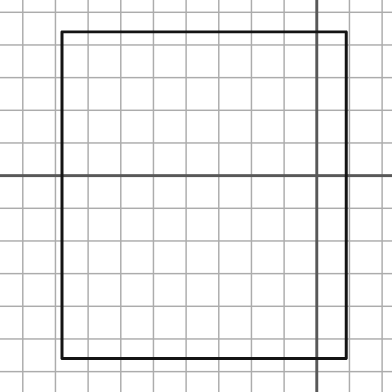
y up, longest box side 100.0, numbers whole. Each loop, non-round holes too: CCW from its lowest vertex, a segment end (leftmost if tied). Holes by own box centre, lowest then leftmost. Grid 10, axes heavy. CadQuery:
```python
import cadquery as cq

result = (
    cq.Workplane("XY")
    .moveTo(-78.0, -56.0)
    .lineTo(9.0, -56.0)
    .lineTo(9.0, 44.0)
    .lineTo(-78.0, 44.0)
    .close()
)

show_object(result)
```